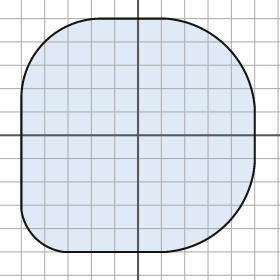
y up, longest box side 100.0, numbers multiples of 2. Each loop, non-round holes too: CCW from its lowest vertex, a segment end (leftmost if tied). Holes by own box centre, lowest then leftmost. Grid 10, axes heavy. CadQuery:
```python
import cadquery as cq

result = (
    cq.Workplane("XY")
    .moveTo(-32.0, -50.0)
    .lineTo(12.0, -50.0)
    .threePointArc((38.0, -38.0), (50.0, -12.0))
    .lineTo(50.0, 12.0)
    .threePointArc((38.0, 38.0), (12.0, 50.0))
    .lineTo(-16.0, 50.0)
    .threePointArc((-40.0, 40.0), (-50.0, 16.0))
    .lineTo(-50.0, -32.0)
    .threePointArc((-44.0, -44.0), (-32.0, -50.0))
    .close()
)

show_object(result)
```